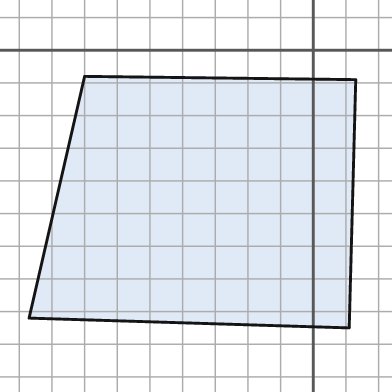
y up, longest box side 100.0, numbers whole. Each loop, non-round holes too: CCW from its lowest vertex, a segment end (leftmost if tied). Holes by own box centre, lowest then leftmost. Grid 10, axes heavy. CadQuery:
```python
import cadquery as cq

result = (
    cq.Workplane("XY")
    .moveTo(11.0, -85.0)
    .lineTo(13.0, -9.0)
    .lineTo(-70.0, -8.0)
    .lineTo(-87.0, -82.0)
    .close()
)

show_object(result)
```